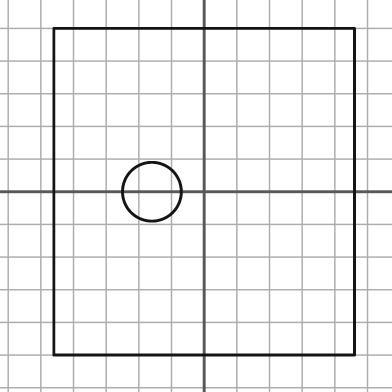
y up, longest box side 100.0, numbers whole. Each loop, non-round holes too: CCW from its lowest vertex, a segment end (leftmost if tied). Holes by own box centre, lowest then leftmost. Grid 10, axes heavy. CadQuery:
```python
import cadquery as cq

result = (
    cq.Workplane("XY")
    .moveTo(-46.0, -50.0)
    .lineTo(46.0, -50.0)
    .lineTo(46.0, 50.0)
    .lineTo(-46.0, 50.0)
    .close()
    .moveTo(-16.0, 0.0)
    .circle(9.0)
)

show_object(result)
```